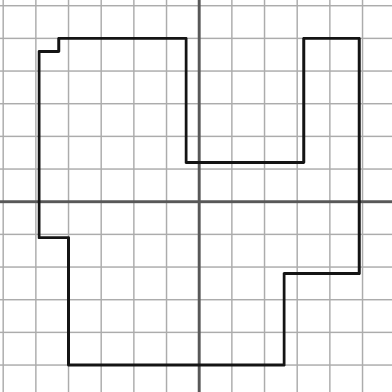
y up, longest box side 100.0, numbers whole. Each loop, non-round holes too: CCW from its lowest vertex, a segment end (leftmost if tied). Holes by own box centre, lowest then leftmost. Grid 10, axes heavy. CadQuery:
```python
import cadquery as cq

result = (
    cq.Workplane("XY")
    .moveTo(-40.0, -50.0)
    .lineTo(26.0, -50.0)
    .lineTo(26.0, -22.0)
    .lineTo(49.0, -22.0)
    .lineTo(49.0, 50.0)
    .lineTo(32.0, 50.0)
    .lineTo(32.0, 12.0)
    .lineTo(-4.0, 12.0)
    .lineTo(-4.0, 50.0)
    .lineTo(-43.0, 50.0)
    .lineTo(-43.0, 46.0)
    .lineTo(-49.0, 46.0)
    .lineTo(-49.0, -11.0)
    .lineTo(-40.0, -11.0)
    .close()
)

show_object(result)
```